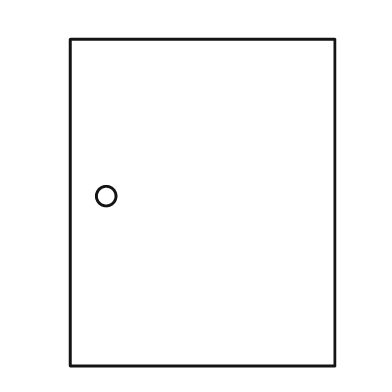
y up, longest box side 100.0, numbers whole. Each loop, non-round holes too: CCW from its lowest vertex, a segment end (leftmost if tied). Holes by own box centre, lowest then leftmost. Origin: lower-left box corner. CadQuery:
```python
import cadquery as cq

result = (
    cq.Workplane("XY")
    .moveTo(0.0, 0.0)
    .lineTo(81.0, 0.0)
    .lineTo(81.0, 100.0)
    .lineTo(0.0, 100.0)
    .close()
    .moveTo(11.0, 52.0)
    .circle(3.0)
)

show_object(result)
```